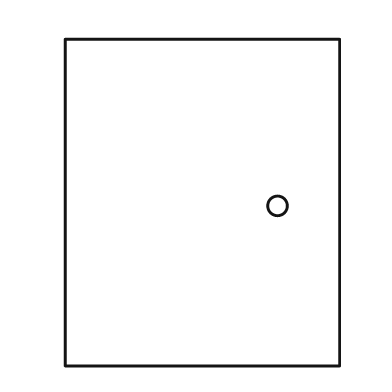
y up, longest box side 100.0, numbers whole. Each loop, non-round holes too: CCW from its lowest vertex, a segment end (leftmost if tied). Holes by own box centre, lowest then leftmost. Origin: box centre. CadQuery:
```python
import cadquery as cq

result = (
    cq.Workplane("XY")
    .moveTo(-42.0, -50.0)
    .lineTo(42.0, -50.0)
    .lineTo(42.0, 50.0)
    .lineTo(-42.0, 50.0)
    .close()
    .moveTo(23.0, -1.0)
    .circle(3.0)
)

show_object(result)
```